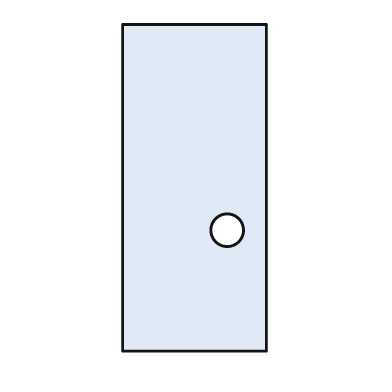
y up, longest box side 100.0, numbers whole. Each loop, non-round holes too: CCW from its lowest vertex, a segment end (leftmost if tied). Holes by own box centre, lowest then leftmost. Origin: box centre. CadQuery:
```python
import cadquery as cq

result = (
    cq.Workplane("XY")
    .moveTo(-22.0, -50.0)
    .lineTo(22.0, -50.0)
    .lineTo(22.0, 50.0)
    .lineTo(-22.0, 50.0)
    .close()
    .moveTo(10.0, -13.0)
    .circle(5.0)
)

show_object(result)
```